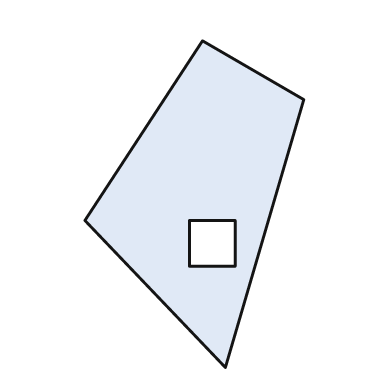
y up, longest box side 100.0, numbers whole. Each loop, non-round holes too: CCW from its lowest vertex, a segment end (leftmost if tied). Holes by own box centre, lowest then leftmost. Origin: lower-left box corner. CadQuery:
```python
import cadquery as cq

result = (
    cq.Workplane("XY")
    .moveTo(43.0, 0.0)
    .lineTo(67.0, 82.0)
    .lineTo(36.0, 100.0)
    .lineTo(0.0, 45.0)
    .close()
    .moveTo(32.0, 31.0)
    .lineTo(46.0, 31.0)
    .lineTo(46.0, 45.0)
    .lineTo(32.0, 45.0)
    .close()
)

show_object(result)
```